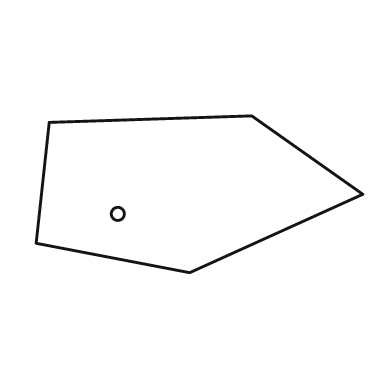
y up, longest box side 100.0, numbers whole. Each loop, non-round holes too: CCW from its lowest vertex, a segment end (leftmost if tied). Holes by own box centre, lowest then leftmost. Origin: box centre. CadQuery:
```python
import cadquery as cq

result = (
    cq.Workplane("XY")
    .moveTo(-3.0, -24.0)
    .lineTo(50.0, 0.0)
    .lineTo(16.0, 24.0)
    .lineTo(-46.0, 22.0)
    .lineTo(-50.0, -15.0)
    .close()
    .moveTo(-25.0, -6.0)
    .circle(2.0)
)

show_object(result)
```